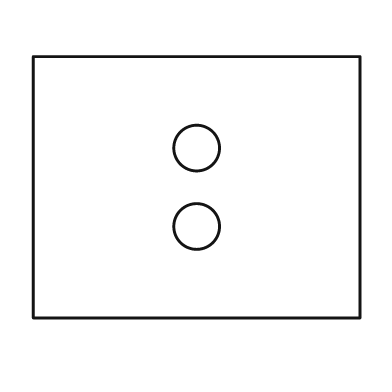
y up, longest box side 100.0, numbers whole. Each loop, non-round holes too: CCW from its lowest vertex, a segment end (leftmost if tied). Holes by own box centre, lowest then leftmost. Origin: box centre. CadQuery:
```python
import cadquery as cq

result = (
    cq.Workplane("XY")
    .moveTo(-50.0, -40.0)
    .lineTo(50.0, -40.0)
    .lineTo(50.0, 40.0)
    .lineTo(-50.0, 40.0)
    .close()
    .moveTo(0.0, -12.0)
    .circle(7.0)
    .moveTo(0.0, 12.0)
    .circle(7.0)
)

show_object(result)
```